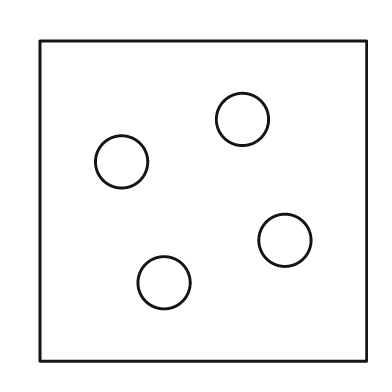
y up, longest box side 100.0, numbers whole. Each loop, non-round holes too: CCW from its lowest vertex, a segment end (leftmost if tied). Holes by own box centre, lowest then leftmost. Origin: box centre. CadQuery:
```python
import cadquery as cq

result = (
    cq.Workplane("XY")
    .moveTo(-50.0, -49.0)
    .lineTo(50.0, -49.0)
    .lineTo(50.0, 49.0)
    .lineTo(-50.0, 49.0)
    .close()
    .moveTo(-12.0, -25.0)
    .circle(8.0)
    .moveTo(25.0, -12.0)
    .circle(8.0)
    .moveTo(-25.0, 12.0)
    .circle(8.0)
    .moveTo(12.0, 25.0)
    .circle(8.0)
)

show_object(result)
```